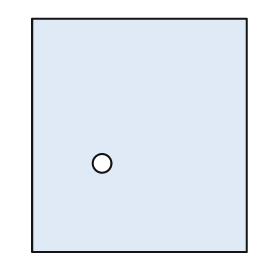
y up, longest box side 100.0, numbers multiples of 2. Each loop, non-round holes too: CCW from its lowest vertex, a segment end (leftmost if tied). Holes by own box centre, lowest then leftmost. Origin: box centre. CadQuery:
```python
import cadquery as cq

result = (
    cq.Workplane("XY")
    .moveTo(-46.0, -50.0)
    .lineTo(46.0, -50.0)
    .lineTo(46.0, 50.0)
    .lineTo(-46.0, 50.0)
    .close()
    .moveTo(-16.0, -12.0)
    .circle(4.0)
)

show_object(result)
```